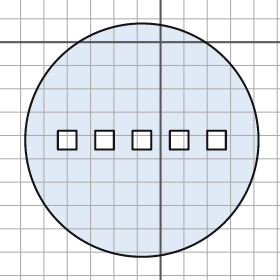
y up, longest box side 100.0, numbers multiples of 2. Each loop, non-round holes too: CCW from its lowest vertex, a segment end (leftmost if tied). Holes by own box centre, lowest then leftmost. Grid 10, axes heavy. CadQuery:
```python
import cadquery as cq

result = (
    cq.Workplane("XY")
    .moveTo(-8.0, -42.0)
    .circle(50.0)
    .moveTo(-44.0, -46.0)
    .lineTo(-36.0, -46.0)
    .lineTo(-36.0, -38.0)
    .lineTo(-44.0, -38.0)
    .close()
    .moveTo(-28.0, -46.0)
    .lineTo(-20.0, -46.0)
    .lineTo(-20.0, -38.0)
    .lineTo(-28.0, -38.0)
    .close()
    .moveTo(-12.0, -46.0)
    .lineTo(-4.0, -46.0)
    .lineTo(-4.0, -38.0)
    .lineTo(-12.0, -38.0)
    .close()
    .moveTo(4.0, -46.0)
    .lineTo(12.0, -46.0)
    .lineTo(12.0, -38.0)
    .lineTo(4.0, -38.0)
    .close()
    .moveTo(20.0, -46.0)
    .lineTo(28.0, -46.0)
    .lineTo(28.0, -38.0)
    .lineTo(20.0, -38.0)
    .close()
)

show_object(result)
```